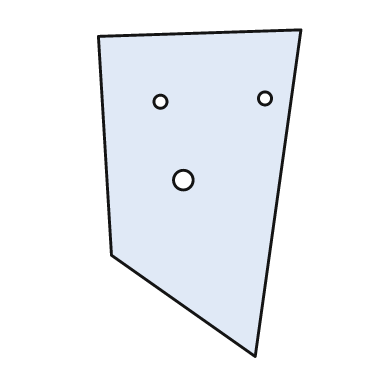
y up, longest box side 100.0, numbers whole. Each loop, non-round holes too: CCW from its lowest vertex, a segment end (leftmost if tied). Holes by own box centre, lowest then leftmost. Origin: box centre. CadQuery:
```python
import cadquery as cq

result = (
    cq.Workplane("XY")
    .moveTo(17.0, -50.0)
    .lineTo(31.0, 50.0)
    .lineTo(-31.0, 48.0)
    .lineTo(-27.0, -19.0)
    .close()
    .moveTo(-5.0, 4.0)
    .circle(3.0)
    .moveTo(-12.0, 28.0)
    .circle(2.0)
    .moveTo(20.0, 29.0)
    .circle(2.0)
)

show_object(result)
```